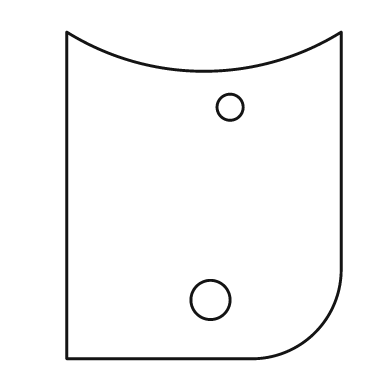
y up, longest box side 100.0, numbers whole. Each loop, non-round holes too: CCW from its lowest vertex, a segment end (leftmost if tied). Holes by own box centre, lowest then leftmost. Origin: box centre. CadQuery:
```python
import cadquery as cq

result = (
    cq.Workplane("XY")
    .moveTo(-42.0, -50.0)
    .lineTo(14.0, -50.0)
    .threePointArc((34.0, -42.0), (42.0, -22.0))
    .lineTo(42.0, 50.0)
    .threePointArc((0.0, 38.0), (-42.0, 50.0))
    .close()
    .moveTo(2.0, -32.0)
    .circle(6.0)
    .moveTo(8.0, 27.0)
    .circle(4.0)
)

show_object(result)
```